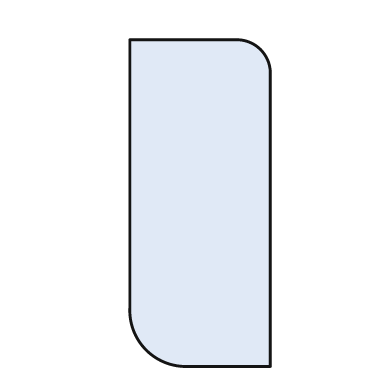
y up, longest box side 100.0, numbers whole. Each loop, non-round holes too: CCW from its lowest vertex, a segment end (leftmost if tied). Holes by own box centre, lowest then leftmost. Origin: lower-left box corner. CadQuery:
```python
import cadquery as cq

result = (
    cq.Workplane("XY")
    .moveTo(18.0, 0.0)
    .lineTo(43.0, 0.0)
    .lineTo(43.0, 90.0)
    .threePointArc((40.0, 97.0), (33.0, 100.0))
    .lineTo(0.0, 100.0)
    .lineTo(0.0, 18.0)
    .threePointArc((5.0, 5.0), (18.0, 0.0))
    .close()
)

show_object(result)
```